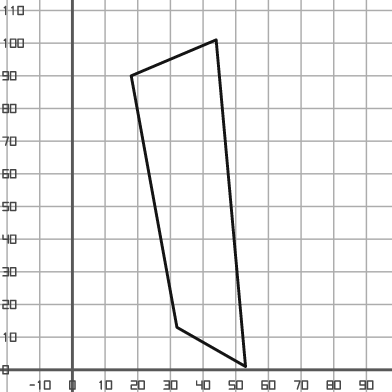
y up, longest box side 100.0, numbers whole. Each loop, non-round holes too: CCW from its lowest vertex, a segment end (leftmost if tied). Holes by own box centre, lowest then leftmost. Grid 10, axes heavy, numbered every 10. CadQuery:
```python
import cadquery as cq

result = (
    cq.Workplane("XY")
    .moveTo(53.0, 1.0)
    .lineTo(44.0, 101.0)
    .lineTo(18.0, 90.0)
    .lineTo(32.0, 13.0)
    .close()
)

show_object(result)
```